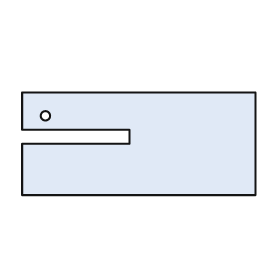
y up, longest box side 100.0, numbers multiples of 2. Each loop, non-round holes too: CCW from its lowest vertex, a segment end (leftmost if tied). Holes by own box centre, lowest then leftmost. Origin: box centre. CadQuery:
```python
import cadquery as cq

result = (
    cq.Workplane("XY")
    .moveTo(-50.0, -22.0)
    .lineTo(50.0, -22.0)
    .lineTo(50.0, 22.0)
    .lineTo(-50.0, 22.0)
    .lineTo(-50.0, 6.0)
    .lineTo(-4.0, 6.0)
    .lineTo(-4.0, 0.0)
    .lineTo(-50.0, 0.0)
    .close()
    .moveTo(-40.0, 12.0)
    .circle(2.0)
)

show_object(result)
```